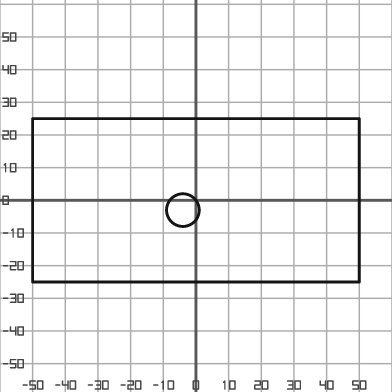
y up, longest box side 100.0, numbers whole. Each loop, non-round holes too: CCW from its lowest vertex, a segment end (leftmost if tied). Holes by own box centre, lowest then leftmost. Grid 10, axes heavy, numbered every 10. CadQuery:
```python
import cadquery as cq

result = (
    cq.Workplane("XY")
    .moveTo(-50.0, -25.0)
    .lineTo(50.0, -25.0)
    .lineTo(50.0, 25.0)
    .lineTo(-50.0, 25.0)
    .close()
    .moveTo(-4.0, -3.0)
    .circle(5.0)
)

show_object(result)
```